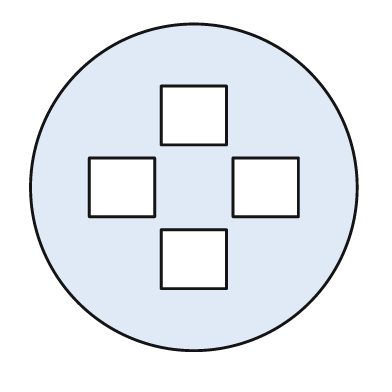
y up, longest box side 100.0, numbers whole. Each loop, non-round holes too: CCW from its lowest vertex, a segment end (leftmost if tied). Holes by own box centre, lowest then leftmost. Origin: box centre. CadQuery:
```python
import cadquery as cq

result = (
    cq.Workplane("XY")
    .moveTo(0.0, 0.0)
    .circle(50.0)
    .moveTo(-10.0, -31.0)
    .lineTo(10.0, -31.0)
    .lineTo(10.0, -13.0)
    .lineTo(-10.0, -13.0)
    .close()
    .moveTo(-32.0, -9.0)
    .lineTo(-12.0, -9.0)
    .lineTo(-12.0, 9.0)
    .lineTo(-32.0, 9.0)
    .close()
    .moveTo(12.0, -9.0)
    .lineTo(32.0, -9.0)
    .lineTo(32.0, 9.0)
    .lineTo(12.0, 9.0)
    .close()
    .moveTo(-10.0, 13.0)
    .lineTo(10.0, 13.0)
    .lineTo(10.0, 31.0)
    .lineTo(-10.0, 31.0)
    .close()
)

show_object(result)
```